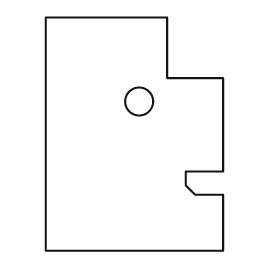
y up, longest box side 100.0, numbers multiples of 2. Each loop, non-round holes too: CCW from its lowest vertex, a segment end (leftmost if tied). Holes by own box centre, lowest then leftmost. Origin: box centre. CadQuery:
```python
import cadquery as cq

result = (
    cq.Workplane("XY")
    .moveTo(-38.0, -50.0)
    .lineTo(38.0, -50.0)
    .lineTo(38.0, -26.0)
    .lineTo(26.0, -26.0)
    .lineTo(22.0, -22.0)
    .lineTo(22.0, -16.0)
    .lineTo(38.0, -16.0)
    .lineTo(38.0, 24.0)
    .lineTo(14.0, 24.0)
    .lineTo(14.0, 50.0)
    .lineTo(-38.0, 50.0)
    .close()
    .moveTo(2.0, 14.0)
    .circle(6.0)
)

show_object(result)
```